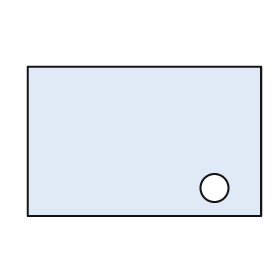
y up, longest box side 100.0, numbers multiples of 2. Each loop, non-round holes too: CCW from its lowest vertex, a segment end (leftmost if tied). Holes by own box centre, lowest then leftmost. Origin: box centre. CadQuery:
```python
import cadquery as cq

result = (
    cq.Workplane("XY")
    .moveTo(-50.0, -32.0)
    .lineTo(50.0, -32.0)
    .lineTo(50.0, 32.0)
    .lineTo(-50.0, 32.0)
    .close()
    .moveTo(30.0, -20.0)
    .circle(6.0)
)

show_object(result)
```